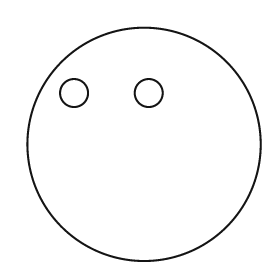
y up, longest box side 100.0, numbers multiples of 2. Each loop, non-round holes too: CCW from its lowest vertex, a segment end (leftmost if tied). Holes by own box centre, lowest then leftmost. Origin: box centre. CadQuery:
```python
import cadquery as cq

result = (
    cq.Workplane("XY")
    .moveTo(0.0, 0.0)
    .circle(50.0)
    .moveTo(-30.0, 22.0)
    .circle(6.0)
    .moveTo(2.0, 22.0)
    .circle(6.0)
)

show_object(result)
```